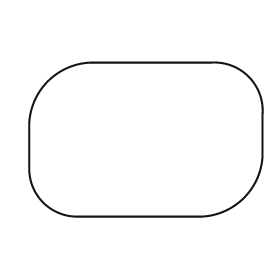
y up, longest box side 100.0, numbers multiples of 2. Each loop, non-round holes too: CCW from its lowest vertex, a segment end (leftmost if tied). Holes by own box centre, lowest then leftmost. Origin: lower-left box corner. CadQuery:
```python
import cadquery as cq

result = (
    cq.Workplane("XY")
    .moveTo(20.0, 0.0)
    .lineTo(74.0, 0.0)
    .threePointArc((92.0, 8.0), (100.0, 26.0))
    .lineTo(100.0, 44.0)
    .threePointArc((94.0, 60.0), (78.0, 66.0))
    .lineTo(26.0, 66.0)
    .threePointArc((8.0, 58.0), (0.0, 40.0))
    .lineTo(0.0, 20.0)
    .threePointArc((6.0, 6.0), (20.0, 0.0))
    .close()
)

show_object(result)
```